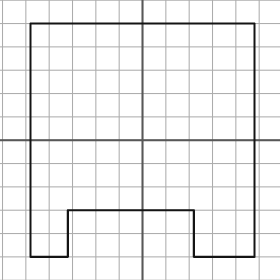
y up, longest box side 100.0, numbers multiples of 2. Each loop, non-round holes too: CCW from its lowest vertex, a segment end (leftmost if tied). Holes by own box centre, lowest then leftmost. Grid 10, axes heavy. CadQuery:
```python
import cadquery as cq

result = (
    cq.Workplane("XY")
    .moveTo(-48.0, -50.0)
    .lineTo(-32.0, -50.0)
    .lineTo(-32.0, -30.0)
    .lineTo(22.0, -30.0)
    .lineTo(22.0, -50.0)
    .lineTo(48.0, -50.0)
    .lineTo(48.0, 50.0)
    .lineTo(-48.0, 50.0)
    .close()
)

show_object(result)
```